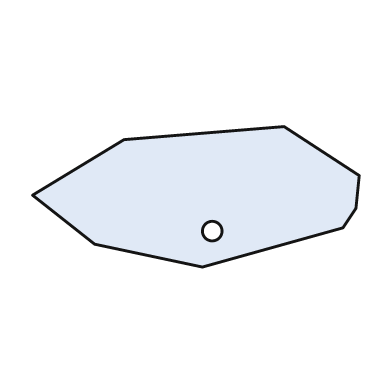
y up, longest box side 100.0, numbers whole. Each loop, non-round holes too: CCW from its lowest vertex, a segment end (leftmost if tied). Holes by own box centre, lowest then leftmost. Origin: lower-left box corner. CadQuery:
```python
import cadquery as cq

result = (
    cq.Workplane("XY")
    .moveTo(52.0, 0.0)
    .lineTo(95.0, 12.0)
    .lineTo(99.0, 18.0)
    .lineTo(100.0, 28.0)
    .lineTo(77.0, 43.0)
    .lineTo(28.0, 39.0)
    .lineTo(0.0, 22.0)
    .lineTo(19.0, 7.0)
    .close()
    .moveTo(55.0, 11.0)
    .circle(3.0)
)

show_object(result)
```